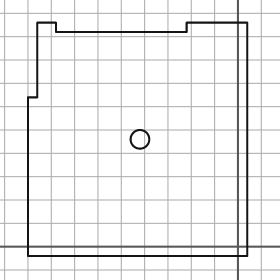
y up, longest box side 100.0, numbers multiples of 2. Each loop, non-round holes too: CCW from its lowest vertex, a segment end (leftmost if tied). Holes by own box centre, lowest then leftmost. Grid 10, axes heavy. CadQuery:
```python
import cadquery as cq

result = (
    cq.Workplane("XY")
    .moveTo(-90.0, -4.0)
    .lineTo(4.0, -4.0)
    .lineTo(4.0, 96.0)
    .lineTo(-22.0, 96.0)
    .lineTo(-22.0, 92.0)
    .lineTo(-78.0, 92.0)
    .lineTo(-78.0, 96.0)
    .lineTo(-86.0, 96.0)
    .lineTo(-86.0, 64.0)
    .lineTo(-90.0, 64.0)
    .close()
    .moveTo(-42.0, 46.0)
    .circle(4.0)
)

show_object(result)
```